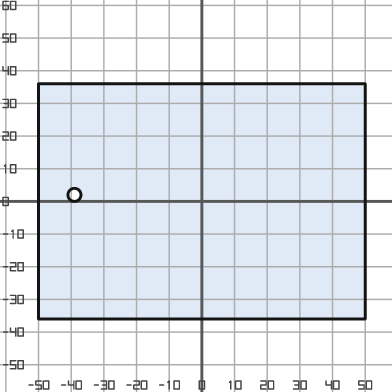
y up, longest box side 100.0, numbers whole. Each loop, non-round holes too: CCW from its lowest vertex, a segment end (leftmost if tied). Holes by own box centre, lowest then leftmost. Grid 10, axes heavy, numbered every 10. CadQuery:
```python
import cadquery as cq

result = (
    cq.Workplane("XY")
    .moveTo(-50.0, -36.0)
    .lineTo(50.0, -36.0)
    .lineTo(50.0, 36.0)
    .lineTo(-50.0, 36.0)
    .close()
    .moveTo(-39.0, 2.0)
    .circle(2.0)
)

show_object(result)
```